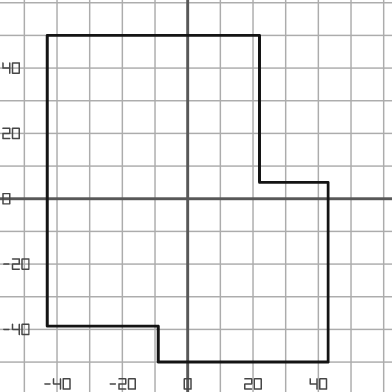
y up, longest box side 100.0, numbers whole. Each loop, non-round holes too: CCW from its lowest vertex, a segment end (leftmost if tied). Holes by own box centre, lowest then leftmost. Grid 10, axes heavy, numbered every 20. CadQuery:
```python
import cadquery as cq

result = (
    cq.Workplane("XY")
    .moveTo(-9.0, -50.0)
    .lineTo(43.0, -50.0)
    .lineTo(43.0, 5.0)
    .lineTo(22.0, 5.0)
    .lineTo(22.0, 50.0)
    .lineTo(-43.0, 50.0)
    .lineTo(-43.0, -39.0)
    .lineTo(-9.0, -39.0)
    .close()
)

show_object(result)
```